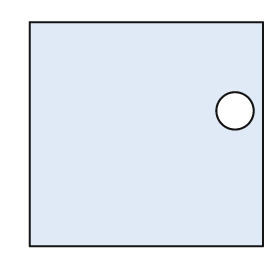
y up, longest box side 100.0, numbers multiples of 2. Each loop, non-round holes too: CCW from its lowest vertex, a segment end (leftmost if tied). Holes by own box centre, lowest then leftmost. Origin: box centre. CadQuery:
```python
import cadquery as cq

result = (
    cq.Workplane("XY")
    .moveTo(-50.0, -48.0)
    .lineTo(50.0, -48.0)
    .lineTo(50.0, 48.0)
    .lineTo(-50.0, 48.0)
    .close()
    .moveTo(38.0, 10.0)
    .circle(8.0)
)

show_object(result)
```